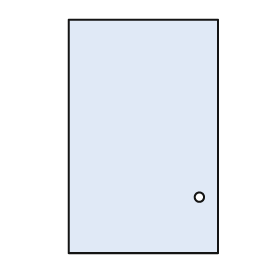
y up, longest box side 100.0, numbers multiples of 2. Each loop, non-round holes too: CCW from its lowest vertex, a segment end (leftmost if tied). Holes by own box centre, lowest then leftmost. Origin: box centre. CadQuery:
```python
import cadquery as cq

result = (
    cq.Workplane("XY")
    .moveTo(-32.0, -50.0)
    .lineTo(32.0, -50.0)
    .lineTo(32.0, 50.0)
    .lineTo(-32.0, 50.0)
    .close()
    .moveTo(24.0, -26.0)
    .circle(2.0)
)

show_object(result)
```